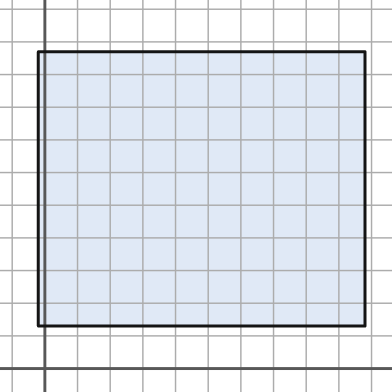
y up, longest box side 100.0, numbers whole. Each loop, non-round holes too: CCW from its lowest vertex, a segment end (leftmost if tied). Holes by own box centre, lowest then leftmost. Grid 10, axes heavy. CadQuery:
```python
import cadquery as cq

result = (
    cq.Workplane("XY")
    .moveTo(-2.0, 13.0)
    .lineTo(98.0, 13.0)
    .lineTo(98.0, 97.0)
    .lineTo(-2.0, 97.0)
    .close()
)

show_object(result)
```